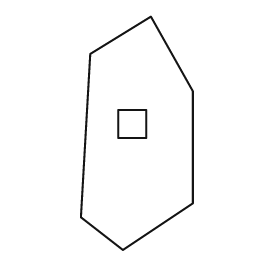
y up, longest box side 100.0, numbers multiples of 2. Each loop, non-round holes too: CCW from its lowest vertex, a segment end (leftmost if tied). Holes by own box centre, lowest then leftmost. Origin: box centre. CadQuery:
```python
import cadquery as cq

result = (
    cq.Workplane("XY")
    .moveTo(-6.0, -50.0)
    .lineTo(24.0, -30.0)
    .lineTo(24.0, 18.0)
    .lineTo(6.0, 50.0)
    .lineTo(-20.0, 34.0)
    .lineTo(-24.0, -36.0)
    .close()
    .moveTo(-8.0, -2.0)
    .lineTo(4.0, -2.0)
    .lineTo(4.0, 10.0)
    .lineTo(-8.0, 10.0)
    .close()
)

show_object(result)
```